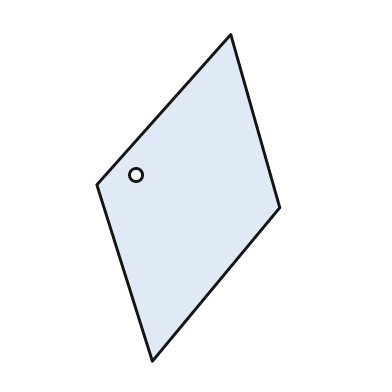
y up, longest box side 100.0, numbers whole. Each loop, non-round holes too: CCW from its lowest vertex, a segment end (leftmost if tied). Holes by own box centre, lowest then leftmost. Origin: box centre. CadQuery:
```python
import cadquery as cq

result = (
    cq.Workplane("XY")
    .moveTo(-11.0, -50.0)
    .lineTo(28.0, -3.0)
    .lineTo(13.0, 50.0)
    .lineTo(-28.0, 4.0)
    .close()
    .moveTo(-16.0, 7.0)
    .circle(2.0)
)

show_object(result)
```